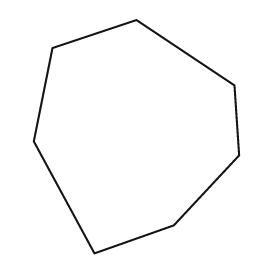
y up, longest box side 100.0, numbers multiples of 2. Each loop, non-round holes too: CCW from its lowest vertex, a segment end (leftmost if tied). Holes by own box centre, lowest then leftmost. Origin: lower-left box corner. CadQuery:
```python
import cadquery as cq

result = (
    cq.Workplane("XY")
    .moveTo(26.0, 0.0)
    .lineTo(60.0, 12.0)
    .lineTo(88.0, 42.0)
    .lineTo(86.0, 72.0)
    .lineTo(44.0, 100.0)
    .lineTo(8.0, 88.0)
    .lineTo(0.0, 48.0)
    .close()
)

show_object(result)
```